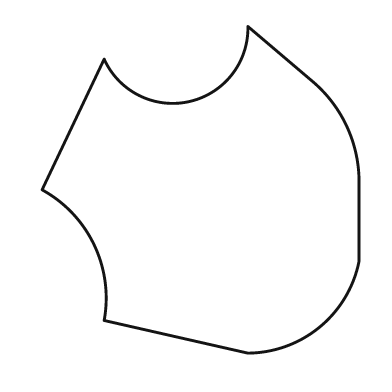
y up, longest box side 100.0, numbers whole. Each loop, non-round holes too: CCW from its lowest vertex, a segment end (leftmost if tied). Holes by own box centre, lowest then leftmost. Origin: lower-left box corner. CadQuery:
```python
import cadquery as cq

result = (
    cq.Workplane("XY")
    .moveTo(63.0, 0.0)
    .threePointArc((85.0, 8.0), (97.0, 28.0))
    .lineTo(97.0, 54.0)
    .threePointArc((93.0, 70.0), (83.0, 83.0))
    .lineTo(63.0, 100.0)
    .threePointArc((45.0, 77.0), (19.0, 90.0))
    .lineTo(0.0, 50.0)
    .threePointArc((16.0, 33.0), (19.0, 10.0))
    .close()
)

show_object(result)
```